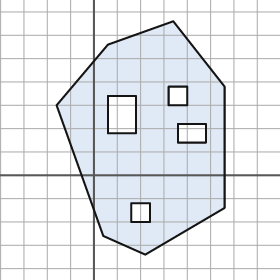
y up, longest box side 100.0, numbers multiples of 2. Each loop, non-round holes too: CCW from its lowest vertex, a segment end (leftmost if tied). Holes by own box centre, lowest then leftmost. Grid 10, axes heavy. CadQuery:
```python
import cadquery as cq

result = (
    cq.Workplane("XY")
    .moveTo(22.0, -34.0)
    .lineTo(56.0, -14.0)
    .lineTo(56.0, 38.0)
    .lineTo(34.0, 66.0)
    .lineTo(6.0, 56.0)
    .lineTo(-16.0, 30.0)
    .lineTo(4.0, -26.0)
    .close()
    .moveTo(16.0, -20.0)
    .lineTo(24.0, -20.0)
    .lineTo(24.0, -12.0)
    .lineTo(16.0, -12.0)
    .close()
    .moveTo(36.0, 14.0)
    .lineTo(48.0, 14.0)
    .lineTo(48.0, 22.0)
    .lineTo(36.0, 22.0)
    .close()
    .moveTo(6.0, 18.0)
    .lineTo(18.0, 18.0)
    .lineTo(18.0, 34.0)
    .lineTo(6.0, 34.0)
    .close()
    .moveTo(32.0, 30.0)
    .lineTo(40.0, 30.0)
    .lineTo(40.0, 38.0)
    .lineTo(32.0, 38.0)
    .close()
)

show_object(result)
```